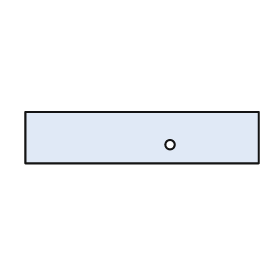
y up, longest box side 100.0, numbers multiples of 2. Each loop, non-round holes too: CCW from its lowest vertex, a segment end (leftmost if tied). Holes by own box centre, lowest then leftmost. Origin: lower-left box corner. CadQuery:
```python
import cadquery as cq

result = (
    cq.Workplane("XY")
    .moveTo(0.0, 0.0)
    .lineTo(100.0, 0.0)
    .lineTo(100.0, 22.0)
    .lineTo(0.0, 22.0)
    .close()
    .moveTo(62.0, 8.0)
    .circle(2.0)
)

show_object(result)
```